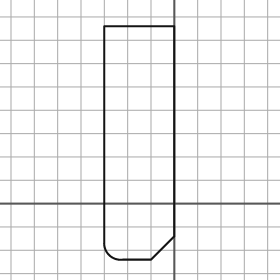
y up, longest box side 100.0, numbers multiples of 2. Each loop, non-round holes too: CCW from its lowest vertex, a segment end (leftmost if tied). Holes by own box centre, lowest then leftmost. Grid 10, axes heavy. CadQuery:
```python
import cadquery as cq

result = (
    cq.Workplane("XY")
    .moveTo(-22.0, -24.0)
    .lineTo(-10.0, -24.0)
    .lineTo(0.0, -14.0)
    .lineTo(0.0, 76.0)
    .lineTo(-30.0, 76.0)
    .lineTo(-30.0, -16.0)
    .threePointArc((-28.0, -22.0), (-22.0, -24.0))
    .close()
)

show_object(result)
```